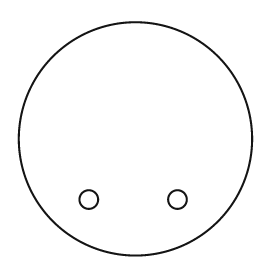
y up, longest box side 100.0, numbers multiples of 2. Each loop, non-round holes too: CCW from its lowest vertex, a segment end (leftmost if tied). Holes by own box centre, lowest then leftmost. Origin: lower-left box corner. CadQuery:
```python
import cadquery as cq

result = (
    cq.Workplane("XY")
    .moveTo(50.0, 50.0)
    .circle(50.0)
    .moveTo(30.0, 24.0)
    .circle(4.0)
    .moveTo(68.0, 24.0)
    .circle(4.0)
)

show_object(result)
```